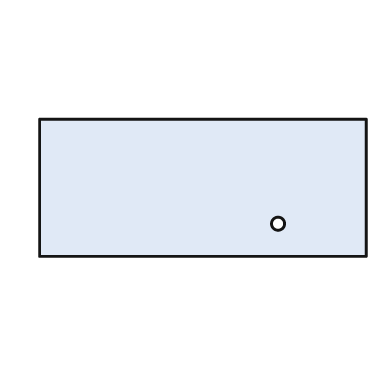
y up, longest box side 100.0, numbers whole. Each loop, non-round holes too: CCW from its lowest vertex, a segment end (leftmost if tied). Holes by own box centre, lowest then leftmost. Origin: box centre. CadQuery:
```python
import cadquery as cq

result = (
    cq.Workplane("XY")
    .moveTo(-50.0, -21.0)
    .lineTo(50.0, -21.0)
    .lineTo(50.0, 21.0)
    .lineTo(-50.0, 21.0)
    .close()
    .moveTo(23.0, -11.0)
    .circle(2.0)
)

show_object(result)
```